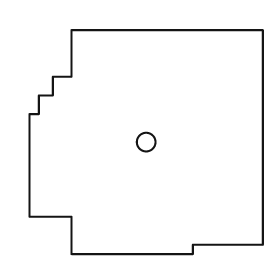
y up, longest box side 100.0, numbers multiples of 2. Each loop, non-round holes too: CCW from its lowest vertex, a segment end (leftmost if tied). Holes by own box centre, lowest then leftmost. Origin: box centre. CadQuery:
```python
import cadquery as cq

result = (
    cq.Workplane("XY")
    .moveTo(-32.0, -48.0)
    .lineTo(20.0, -48.0)
    .lineTo(20.0, -44.0)
    .lineTo(50.0, -44.0)
    .lineTo(50.0, 48.0)
    .lineTo(-32.0, 48.0)
    .lineTo(-32.0, 28.0)
    .lineTo(-40.0, 28.0)
    .lineTo(-40.0, 20.0)
    .lineTo(-46.0, 20.0)
    .lineTo(-46.0, 12.0)
    .lineTo(-50.0, 12.0)
    .lineTo(-50.0, -32.0)
    .lineTo(-32.0, -32.0)
    .close()
    .moveTo(0.0, 0.0)
    .circle(4.0)
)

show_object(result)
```